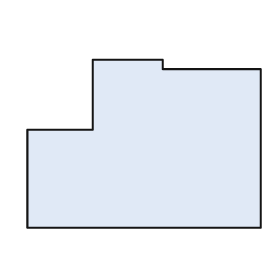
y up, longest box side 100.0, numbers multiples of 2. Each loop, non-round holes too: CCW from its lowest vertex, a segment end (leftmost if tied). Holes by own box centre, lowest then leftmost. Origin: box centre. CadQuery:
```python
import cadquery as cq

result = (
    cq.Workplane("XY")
    .moveTo(-50.0, -36.0)
    .lineTo(50.0, -36.0)
    .lineTo(50.0, 32.0)
    .lineTo(8.0, 32.0)
    .lineTo(8.0, 36.0)
    .lineTo(-22.0, 36.0)
    .lineTo(-22.0, 6.0)
    .lineTo(-50.0, 6.0)
    .close()
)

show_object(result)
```